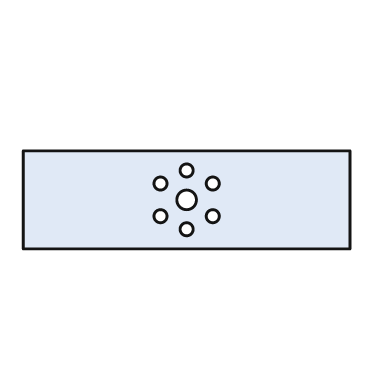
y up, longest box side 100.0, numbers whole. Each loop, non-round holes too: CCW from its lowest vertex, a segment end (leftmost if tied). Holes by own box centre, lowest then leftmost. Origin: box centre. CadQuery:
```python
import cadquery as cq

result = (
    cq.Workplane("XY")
    .moveTo(-50.0, -15.0)
    .lineTo(50.0, -15.0)
    .lineTo(50.0, 15.0)
    .lineTo(-50.0, 15.0)
    .close()
    .moveTo(0.0, -9.0)
    .circle(2.0)
    .moveTo(-8.0, -5.0)
    .circle(2.0)
    .moveTo(8.0, -5.0)
    .circle(2.0)
    .moveTo(0.0, 0.0)
    .circle(3.0)
    .moveTo(-8.0, 5.0)
    .circle(2.0)
    .moveTo(8.0, 5.0)
    .circle(2.0)
    .moveTo(0.0, 9.0)
    .circle(2.0)
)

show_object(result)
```